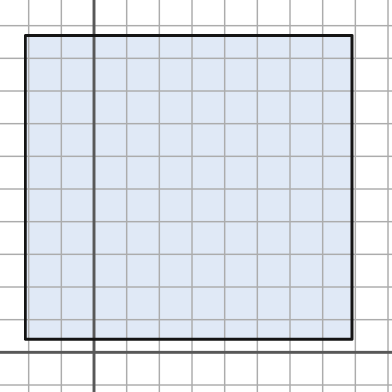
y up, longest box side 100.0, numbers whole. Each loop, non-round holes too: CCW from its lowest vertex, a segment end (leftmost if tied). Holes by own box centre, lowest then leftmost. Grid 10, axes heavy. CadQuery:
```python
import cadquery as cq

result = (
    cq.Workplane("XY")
    .moveTo(-21.0, 4.0)
    .lineTo(79.0, 4.0)
    .lineTo(79.0, 97.0)
    .lineTo(-21.0, 97.0)
    .close()
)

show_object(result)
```